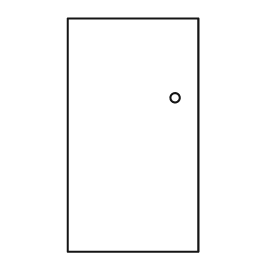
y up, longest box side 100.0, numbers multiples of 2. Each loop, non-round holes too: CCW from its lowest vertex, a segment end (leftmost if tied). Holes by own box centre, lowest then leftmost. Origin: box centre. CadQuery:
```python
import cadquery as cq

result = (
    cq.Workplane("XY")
    .moveTo(-28.0, -50.0)
    .lineTo(28.0, -50.0)
    .lineTo(28.0, 50.0)
    .lineTo(-28.0, 50.0)
    .close()
    .moveTo(18.0, 16.0)
    .circle(2.0)
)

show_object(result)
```